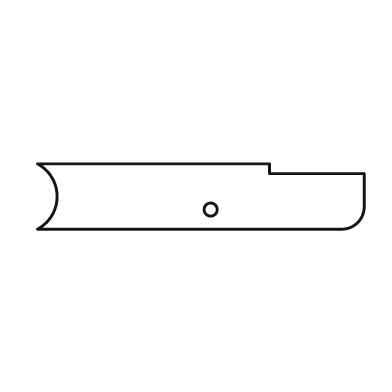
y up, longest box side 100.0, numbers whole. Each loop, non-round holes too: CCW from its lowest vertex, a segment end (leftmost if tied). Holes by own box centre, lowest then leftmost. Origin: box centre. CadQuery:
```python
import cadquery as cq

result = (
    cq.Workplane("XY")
    .moveTo(-50.0, -10.0)
    .lineTo(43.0, -10.0)
    .threePointArc((48.0, -8.0), (50.0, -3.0))
    .lineTo(50.0, 7.0)
    .lineTo(21.0, 7.0)
    .lineTo(21.0, 10.0)
    .lineTo(-50.0, 10.0)
    .threePointArc((-44.0, 0.0), (-50.0, -10.0))
    .close()
    .moveTo(3.0, -4.0)
    .circle(2.0)
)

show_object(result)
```